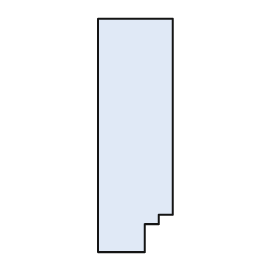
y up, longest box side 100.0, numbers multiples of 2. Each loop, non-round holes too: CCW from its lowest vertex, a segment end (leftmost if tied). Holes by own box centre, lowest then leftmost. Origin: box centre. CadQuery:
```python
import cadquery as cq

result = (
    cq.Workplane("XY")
    .moveTo(-16.0, -50.0)
    .lineTo(4.0, -50.0)
    .lineTo(4.0, -38.0)
    .lineTo(10.0, -38.0)
    .lineTo(10.0, -34.0)
    .lineTo(16.0, -34.0)
    .lineTo(16.0, 50.0)
    .lineTo(-16.0, 50.0)
    .close()
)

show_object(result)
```